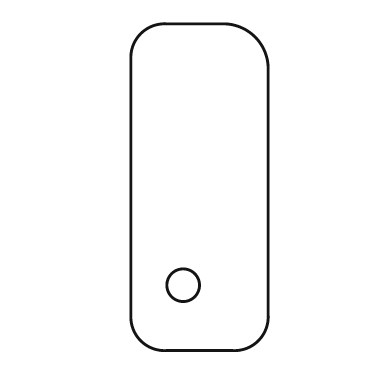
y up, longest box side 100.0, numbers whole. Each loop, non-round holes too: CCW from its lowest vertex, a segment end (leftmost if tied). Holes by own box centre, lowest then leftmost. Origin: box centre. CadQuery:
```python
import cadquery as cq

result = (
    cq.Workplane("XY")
    .moveTo(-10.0, -50.0)
    .lineTo(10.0, -50.0)
    .threePointArc((18.0, -47.0), (21.0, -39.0))
    .lineTo(21.0, 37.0)
    .threePointArc((17.0, 46.0), (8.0, 50.0))
    .lineTo(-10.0, 50.0)
    .threePointArc((-18.0, 47.0), (-21.0, 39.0))
    .lineTo(-21.0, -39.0)
    .threePointArc((-18.0, -47.0), (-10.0, -50.0))
    .close()
    .moveTo(-5.0, -30.0)
    .circle(5.0)
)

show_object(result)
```